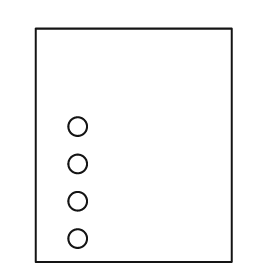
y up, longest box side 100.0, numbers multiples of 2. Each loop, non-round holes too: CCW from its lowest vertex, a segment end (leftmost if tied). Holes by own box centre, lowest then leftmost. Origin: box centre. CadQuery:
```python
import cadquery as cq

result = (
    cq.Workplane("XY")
    .moveTo(-42.0, -50.0)
    .lineTo(42.0, -50.0)
    .lineTo(42.0, 50.0)
    .lineTo(-42.0, 50.0)
    .close()
    .moveTo(-24.0, -40.0)
    .circle(4.0)
    .moveTo(-24.0, -24.0)
    .circle(4.0)
    .moveTo(-24.0, -8.0)
    .circle(4.0)
    .moveTo(-24.0, 8.0)
    .circle(4.0)
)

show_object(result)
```